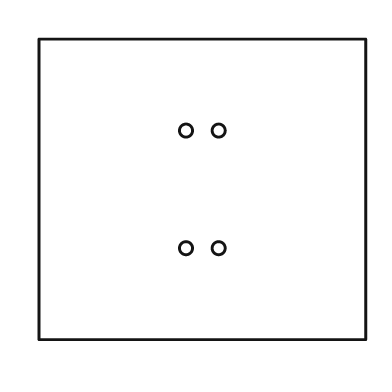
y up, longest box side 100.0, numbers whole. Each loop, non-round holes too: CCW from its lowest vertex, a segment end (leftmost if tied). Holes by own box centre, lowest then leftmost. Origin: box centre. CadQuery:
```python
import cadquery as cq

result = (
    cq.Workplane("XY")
    .moveTo(-50.0, -46.0)
    .lineTo(50.0, -46.0)
    .lineTo(50.0, 46.0)
    .lineTo(-50.0, 46.0)
    .close()
    .moveTo(-5.0, -18.0)
    .circle(2.0)
    .moveTo(5.0, -18.0)
    .circle(2.0)
    .moveTo(-5.0, 18.0)
    .circle(2.0)
    .moveTo(5.0, 18.0)
    .circle(2.0)
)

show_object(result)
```